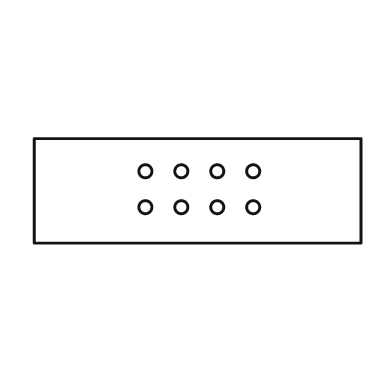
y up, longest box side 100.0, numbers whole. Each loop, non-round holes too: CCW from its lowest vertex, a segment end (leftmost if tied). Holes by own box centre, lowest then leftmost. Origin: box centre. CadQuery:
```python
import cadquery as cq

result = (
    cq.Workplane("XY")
    .moveTo(-50.0, -16.0)
    .lineTo(50.0, -16.0)
    .lineTo(50.0, 16.0)
    .lineTo(-50.0, 16.0)
    .close()
    .moveTo(-16.0, -5.0)
    .circle(2.0)
    .moveTo(-5.0, -5.0)
    .circle(2.0)
    .moveTo(6.0, -5.0)
    .circle(2.0)
    .moveTo(17.0, -5.0)
    .circle(2.0)
    .moveTo(-16.0, 6.0)
    .circle(2.0)
    .moveTo(-5.0, 6.0)
    .circle(2.0)
    .moveTo(6.0, 6.0)
    .circle(2.0)
    .moveTo(17.0, 6.0)
    .circle(2.0)
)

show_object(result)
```